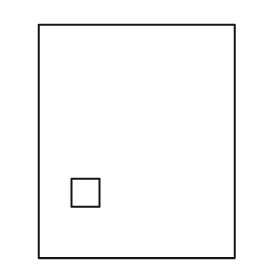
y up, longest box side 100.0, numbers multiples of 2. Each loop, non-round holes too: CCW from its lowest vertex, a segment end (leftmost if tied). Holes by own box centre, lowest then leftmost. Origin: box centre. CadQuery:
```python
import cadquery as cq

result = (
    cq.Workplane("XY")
    .moveTo(-42.0, -50.0)
    .lineTo(42.0, -50.0)
    .lineTo(42.0, 50.0)
    .lineTo(-42.0, 50.0)
    .close()
    .moveTo(-28.0, -28.0)
    .lineTo(-16.0, -28.0)
    .lineTo(-16.0, -16.0)
    .lineTo(-28.0, -16.0)
    .close()
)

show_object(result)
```